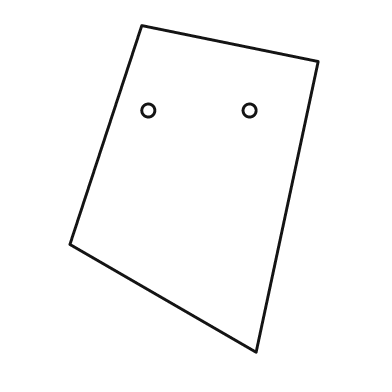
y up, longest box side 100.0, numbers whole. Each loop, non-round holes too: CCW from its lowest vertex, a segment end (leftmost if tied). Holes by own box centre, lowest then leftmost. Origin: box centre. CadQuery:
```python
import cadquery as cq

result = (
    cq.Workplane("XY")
    .moveTo(19.0, -50.0)
    .lineTo(38.0, 39.0)
    .lineTo(-16.0, 50.0)
    .lineTo(-38.0, -17.0)
    .close()
    .moveTo(-14.0, 24.0)
    .circle(2.0)
    .moveTo(17.0, 24.0)
    .circle(2.0)
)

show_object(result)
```